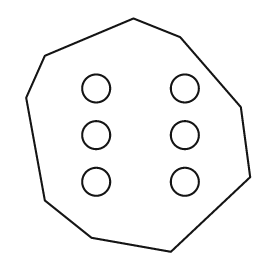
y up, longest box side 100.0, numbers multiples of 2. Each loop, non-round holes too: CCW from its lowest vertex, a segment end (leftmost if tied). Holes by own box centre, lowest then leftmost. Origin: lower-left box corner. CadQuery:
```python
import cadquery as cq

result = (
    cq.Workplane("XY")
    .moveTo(62.0, 0.0)
    .lineTo(96.0, 32.0)
    .lineTo(92.0, 62.0)
    .lineTo(66.0, 92.0)
    .lineTo(46.0, 100.0)
    .lineTo(8.0, 84.0)
    .lineTo(0.0, 66.0)
    .lineTo(8.0, 22.0)
    .lineTo(28.0, 6.0)
    .close()
    .moveTo(30.0, 30.0)
    .circle(6.0)
    .moveTo(68.0, 30.0)
    .circle(6.0)
    .moveTo(30.0, 50.0)
    .circle(6.0)
    .moveTo(68.0, 50.0)
    .circle(6.0)
    .moveTo(30.0, 70.0)
    .circle(6.0)
    .moveTo(68.0, 70.0)
    .circle(6.0)
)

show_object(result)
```